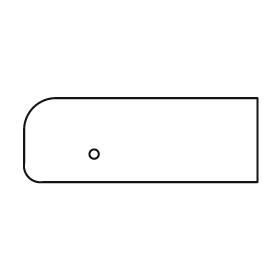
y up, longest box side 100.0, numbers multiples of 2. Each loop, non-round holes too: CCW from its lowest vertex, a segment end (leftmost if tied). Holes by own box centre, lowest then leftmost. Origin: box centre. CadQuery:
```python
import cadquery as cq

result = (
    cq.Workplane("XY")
    .moveTo(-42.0, -18.0)
    .lineTo(50.0, -18.0)
    .lineTo(50.0, 18.0)
    .lineTo(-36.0, 18.0)
    .threePointArc((-46.0, 14.0), (-50.0, 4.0))
    .lineTo(-50.0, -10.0)
    .threePointArc((-48.0, -16.0), (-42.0, -18.0))
    .close()
    .moveTo(-20.0, -6.0)
    .circle(2.0)
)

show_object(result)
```